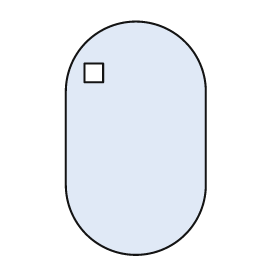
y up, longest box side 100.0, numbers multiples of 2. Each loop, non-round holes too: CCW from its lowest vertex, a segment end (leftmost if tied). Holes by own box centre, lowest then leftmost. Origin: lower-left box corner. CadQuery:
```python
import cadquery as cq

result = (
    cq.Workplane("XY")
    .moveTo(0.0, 30.0)
    .threePointArc((30.0, 0.0), (60.0, 30.0))
    .lineTo(60.0, 70.0)
    .threePointArc((30.0, 100.0), (0.0, 70.0))
    .close()
    .moveTo(8.0, 74.0)
    .lineTo(16.0, 74.0)
    .lineTo(16.0, 82.0)
    .lineTo(8.0, 82.0)
    .close()
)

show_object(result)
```